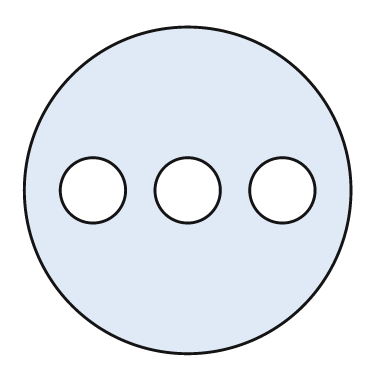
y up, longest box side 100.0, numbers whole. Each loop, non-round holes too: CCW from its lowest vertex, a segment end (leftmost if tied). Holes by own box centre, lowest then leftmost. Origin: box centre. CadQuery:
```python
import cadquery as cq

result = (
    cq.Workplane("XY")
    .moveTo(0.0, 0.0)
    .circle(50.0)
    .moveTo(-29.0, 0.0)
    .circle(10.0)
    .moveTo(0.0, 0.0)
    .circle(10.0)
    .moveTo(29.0, 0.0)
    .circle(10.0)
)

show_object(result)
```